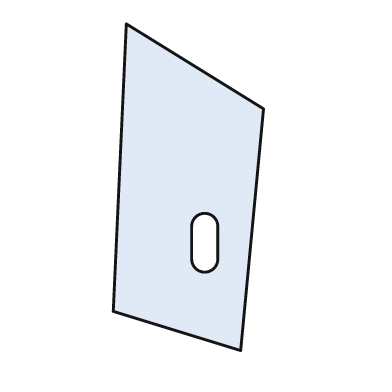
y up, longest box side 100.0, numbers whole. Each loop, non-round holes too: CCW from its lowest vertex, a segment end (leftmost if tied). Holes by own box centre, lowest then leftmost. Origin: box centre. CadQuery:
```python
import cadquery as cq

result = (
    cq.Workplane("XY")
    .moveTo(16.0, -50.0)
    .lineTo(23.0, 24.0)
    .lineTo(-19.0, 50.0)
    .lineTo(-23.0, -38.0)
    .close()
    .moveTo(1.0, -22.0)
    .threePointArc((5.0, -26.0), (9.0, -22.0))
    .lineTo(9.0, -12.0)
    .threePointArc((5.0, -8.0), (1.0, -12.0))
    .close()
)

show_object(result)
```